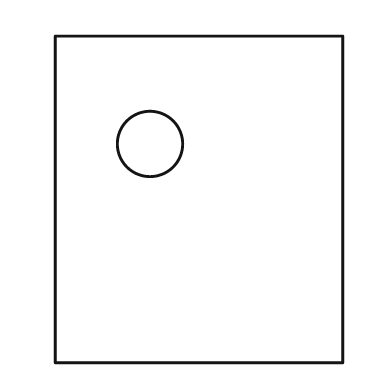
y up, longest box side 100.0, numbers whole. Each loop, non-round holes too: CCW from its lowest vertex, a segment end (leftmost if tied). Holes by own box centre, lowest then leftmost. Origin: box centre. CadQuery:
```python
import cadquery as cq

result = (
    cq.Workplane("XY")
    .moveTo(-44.0, -50.0)
    .lineTo(44.0, -50.0)
    .lineTo(44.0, 50.0)
    .lineTo(-44.0, 50.0)
    .close()
    .moveTo(-15.0, 17.0)
    .circle(10.0)
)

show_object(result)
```